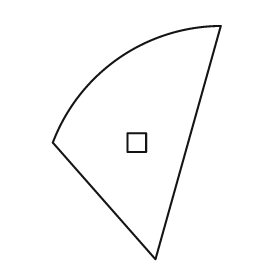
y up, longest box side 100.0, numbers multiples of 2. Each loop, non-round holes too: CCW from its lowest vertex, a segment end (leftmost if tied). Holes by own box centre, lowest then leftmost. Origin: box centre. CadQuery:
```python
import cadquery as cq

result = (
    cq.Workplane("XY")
    .moveTo(8.0, -50.0)
    .lineTo(36.0, 50.0)
    .threePointArc((-8.0, 36.0), (-36.0, 0.0))
    .close()
    .moveTo(-4.0, -4.0)
    .lineTo(4.0, -4.0)
    .lineTo(4.0, 4.0)
    .lineTo(-4.0, 4.0)
    .close()
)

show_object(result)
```